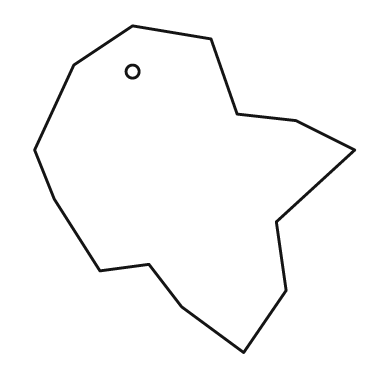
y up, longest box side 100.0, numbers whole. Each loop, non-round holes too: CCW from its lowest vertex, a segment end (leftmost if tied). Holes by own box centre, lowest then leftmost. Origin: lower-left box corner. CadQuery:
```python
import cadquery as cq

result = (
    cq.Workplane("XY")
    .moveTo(64.0, 0.0)
    .lineTo(77.0, 19.0)
    .lineTo(74.0, 40.0)
    .lineTo(98.0, 62.0)
    .lineTo(80.0, 71.0)
    .lineTo(62.0, 73.0)
    .lineTo(54.0, 96.0)
    .lineTo(30.0, 100.0)
    .lineTo(12.0, 88.0)
    .lineTo(0.0, 62.0)
    .lineTo(6.0, 47.0)
    .lineTo(20.0, 25.0)
    .lineTo(35.0, 27.0)
    .lineTo(45.0, 14.0)
    .close()
    .moveTo(30.0, 86.0)
    .circle(2.0)
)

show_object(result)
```